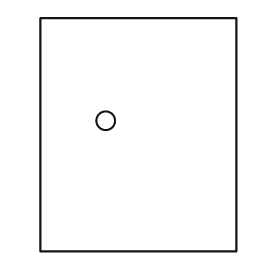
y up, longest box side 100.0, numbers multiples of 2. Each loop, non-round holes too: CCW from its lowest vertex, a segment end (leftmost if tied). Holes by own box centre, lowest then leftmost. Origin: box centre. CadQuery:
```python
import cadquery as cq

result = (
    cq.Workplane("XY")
    .moveTo(-42.0, -50.0)
    .lineTo(42.0, -50.0)
    .lineTo(42.0, 50.0)
    .lineTo(-42.0, 50.0)
    .close()
    .moveTo(-14.0, 6.0)
    .circle(4.0)
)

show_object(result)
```